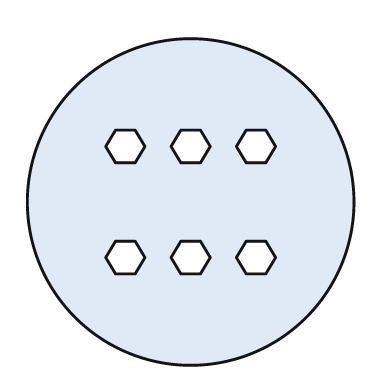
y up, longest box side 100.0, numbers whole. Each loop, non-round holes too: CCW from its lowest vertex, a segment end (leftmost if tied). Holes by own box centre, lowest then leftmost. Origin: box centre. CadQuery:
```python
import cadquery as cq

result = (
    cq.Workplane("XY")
    .moveTo(0.0, 0.0)
    .circle(50.0)
    .moveTo(-23.0, -22.0)
    .lineTo(-17.0, -22.0)
    .lineTo(-14.0, -17.0)
    .lineTo(-17.0, -12.0)
    .lineTo(-23.0, -12.0)
    .lineTo(-26.0, -17.0)
    .close()
    .moveTo(-3.0, -22.0)
    .lineTo(3.0, -22.0)
    .lineTo(6.0, -17.0)
    .lineTo(3.0, -12.0)
    .lineTo(-3.0, -12.0)
    .lineTo(-6.0, -17.0)
    .close()
    .moveTo(17.0, -22.0)
    .lineTo(23.0, -22.0)
    .lineTo(26.0, -17.0)
    .lineTo(23.0, -12.0)
    .lineTo(17.0, -12.0)
    .lineTo(14.0, -17.0)
    .close()
    .moveTo(-23.0, 12.0)
    .lineTo(-17.0, 12.0)
    .lineTo(-14.0, 17.0)
    .lineTo(-17.0, 22.0)
    .lineTo(-23.0, 22.0)
    .lineTo(-26.0, 17.0)
    .close()
    .moveTo(-3.0, 12.0)
    .lineTo(3.0, 12.0)
    .lineTo(6.0, 17.0)
    .lineTo(3.0, 22.0)
    .lineTo(-3.0, 22.0)
    .lineTo(-6.0, 17.0)
    .close()
    .moveTo(17.0, 12.0)
    .lineTo(23.0, 12.0)
    .lineTo(26.0, 17.0)
    .lineTo(23.0, 22.0)
    .lineTo(17.0, 22.0)
    .lineTo(14.0, 17.0)
    .close()
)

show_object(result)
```